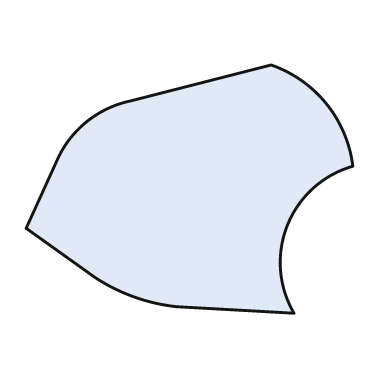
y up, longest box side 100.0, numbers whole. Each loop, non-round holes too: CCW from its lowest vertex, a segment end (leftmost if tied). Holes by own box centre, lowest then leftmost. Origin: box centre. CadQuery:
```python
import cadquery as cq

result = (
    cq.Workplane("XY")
    .moveTo(32.0, -38.0)
    .threePointArc((30.0, -11.0), (50.0, 7.0))
    .threePointArc((42.0, 26.0), (25.0, 38.0))
    .lineTo(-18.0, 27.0)
    .threePointArc((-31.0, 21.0), (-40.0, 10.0))
    .lineTo(-50.0, -12.0)
    .lineTo(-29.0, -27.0)
    .threePointArc((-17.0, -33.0), (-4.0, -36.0))
    .close()
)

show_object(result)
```